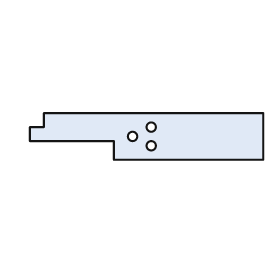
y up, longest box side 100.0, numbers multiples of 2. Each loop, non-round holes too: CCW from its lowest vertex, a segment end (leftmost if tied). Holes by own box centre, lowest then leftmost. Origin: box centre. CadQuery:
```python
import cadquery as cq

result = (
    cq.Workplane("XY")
    .moveTo(-14.0, -10.0)
    .lineTo(50.0, -10.0)
    .lineTo(50.0, 10.0)
    .lineTo(-44.0, 10.0)
    .lineTo(-44.0, 4.0)
    .lineTo(-50.0, 4.0)
    .lineTo(-50.0, -2.0)
    .lineTo(-14.0, -2.0)
    .close()
    .moveTo(2.0, -4.0)
    .circle(2.0)
    .moveTo(-6.0, 0.0)
    .circle(2.0)
    .moveTo(2.0, 4.0)
    .circle(2.0)
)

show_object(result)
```